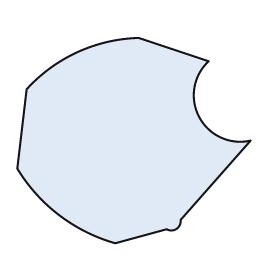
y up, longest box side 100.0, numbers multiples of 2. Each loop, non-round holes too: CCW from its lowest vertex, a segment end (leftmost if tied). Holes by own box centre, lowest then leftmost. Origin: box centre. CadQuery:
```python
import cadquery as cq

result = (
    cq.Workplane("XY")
    .moveTo(-8.0, -44.0)
    .lineTo(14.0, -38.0)
    .threePointArc((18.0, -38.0), (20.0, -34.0))
    .lineTo(50.0, 0.0)
    .threePointArc((28.0, 10.0), (32.0, 34.0))
    .lineTo(2.0, 44.0)
    .threePointArc((-24.0, 38.0), (-46.0, 22.0))
    .lineTo(-50.0, -12.0)
    .threePointArc((-32.0, -32.0), (-8.0, -44.0))
    .close()
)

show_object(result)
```